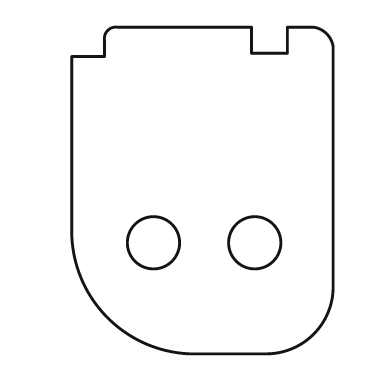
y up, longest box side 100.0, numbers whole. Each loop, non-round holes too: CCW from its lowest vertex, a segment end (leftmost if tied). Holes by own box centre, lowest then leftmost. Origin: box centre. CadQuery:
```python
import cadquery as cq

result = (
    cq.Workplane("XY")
    .moveTo(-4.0, -50.0)
    .lineTo(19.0, -50.0)
    .threePointArc((34.0, -44.0), (40.0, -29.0))
    .lineTo(40.0, 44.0)
    .threePointArc((38.0, 48.0), (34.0, 50.0))
    .lineTo(26.0, 50.0)
    .lineTo(26.0, 42.0)
    .lineTo(15.0, 42.0)
    .lineTo(15.0, 50.0)
    .lineTo(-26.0, 50.0)
    .threePointArc((-29.0, 49.0), (-30.0, 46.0))
    .lineTo(-30.0, 41.0)
    .lineTo(-40.0, 41.0)
    .lineTo(-40.0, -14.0)
    .threePointArc((-29.0, -39.0), (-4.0, -50.0))
    .close()
    .moveTo(-15.0, -16.0)
    .circle(8.0)
    .moveTo(16.0, -16.0)
    .circle(8.0)
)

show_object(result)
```